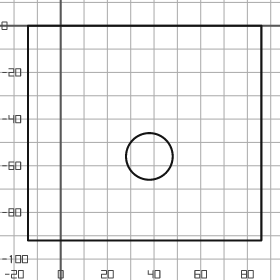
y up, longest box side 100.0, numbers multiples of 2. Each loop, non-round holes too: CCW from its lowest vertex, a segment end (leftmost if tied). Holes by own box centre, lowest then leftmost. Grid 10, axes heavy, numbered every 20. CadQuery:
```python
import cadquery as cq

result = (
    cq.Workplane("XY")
    .moveTo(-14.0, -92.0)
    .lineTo(86.0, -92.0)
    .lineTo(86.0, 0.0)
    .lineTo(-14.0, 0.0)
    .close()
    .moveTo(38.0, -56.0)
    .circle(10.0)
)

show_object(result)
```